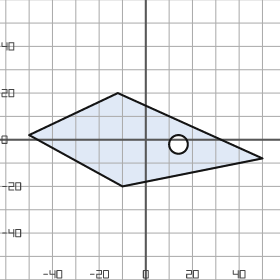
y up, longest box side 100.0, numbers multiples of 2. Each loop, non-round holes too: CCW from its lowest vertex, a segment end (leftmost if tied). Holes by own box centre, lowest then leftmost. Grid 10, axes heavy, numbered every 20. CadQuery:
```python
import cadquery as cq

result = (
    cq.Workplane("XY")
    .moveTo(-10.0, -20.0)
    .lineTo(50.0, -8.0)
    .lineTo(-12.0, 20.0)
    .lineTo(-50.0, 2.0)
    .close()
    .moveTo(14.0, -2.0)
    .circle(4.0)
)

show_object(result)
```